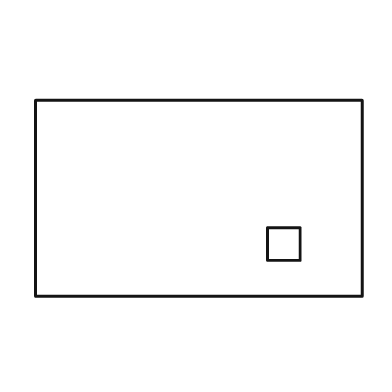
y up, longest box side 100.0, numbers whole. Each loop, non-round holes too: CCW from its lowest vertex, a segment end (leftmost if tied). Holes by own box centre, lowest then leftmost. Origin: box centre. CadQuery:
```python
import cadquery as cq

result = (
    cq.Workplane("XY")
    .moveTo(-50.0, -30.0)
    .lineTo(50.0, -30.0)
    .lineTo(50.0, 30.0)
    .lineTo(-50.0, 30.0)
    .close()
    .moveTo(21.0, -19.0)
    .lineTo(31.0, -19.0)
    .lineTo(31.0, -9.0)
    .lineTo(21.0, -9.0)
    .close()
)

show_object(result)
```